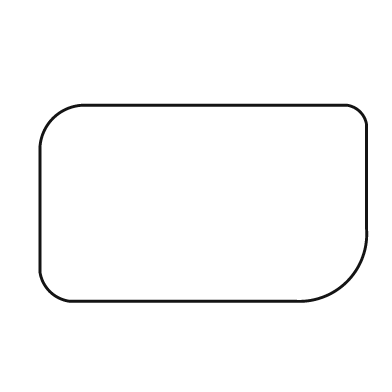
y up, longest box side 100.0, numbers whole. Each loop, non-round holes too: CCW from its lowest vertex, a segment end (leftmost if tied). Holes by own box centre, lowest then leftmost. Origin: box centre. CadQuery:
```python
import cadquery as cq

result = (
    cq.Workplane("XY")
    .moveTo(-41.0, -30.0)
    .lineTo(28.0, -30.0)
    .threePointArc((44.0, -24.0), (50.0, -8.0))
    .lineTo(50.0, 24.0)
    .threePointArc((48.0, 28.0), (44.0, 30.0))
    .lineTo(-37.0, 30.0)
    .threePointArc((-46.0, 26.0), (-50.0, 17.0))
    .lineTo(-50.0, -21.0)
    .threePointArc((-47.0, -27.0), (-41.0, -30.0))
    .close()
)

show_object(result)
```